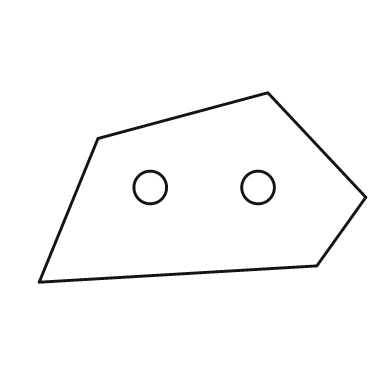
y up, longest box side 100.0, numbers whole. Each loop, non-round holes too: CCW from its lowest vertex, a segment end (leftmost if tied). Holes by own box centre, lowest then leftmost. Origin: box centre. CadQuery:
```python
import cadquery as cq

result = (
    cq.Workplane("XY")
    .moveTo(-50.0, -29.0)
    .lineTo(35.0, -24.0)
    .lineTo(50.0, -3.0)
    .lineTo(20.0, 29.0)
    .lineTo(-32.0, 15.0)
    .close()
    .moveTo(-16.0, 0.0)
    .circle(5.0)
    .moveTo(17.0, 0.0)
    .circle(5.0)
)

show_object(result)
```